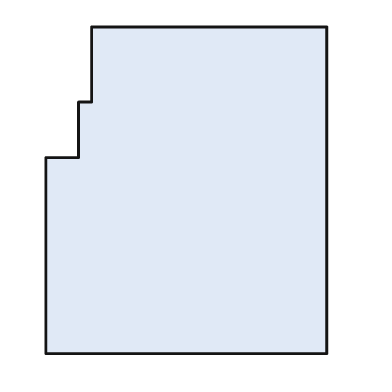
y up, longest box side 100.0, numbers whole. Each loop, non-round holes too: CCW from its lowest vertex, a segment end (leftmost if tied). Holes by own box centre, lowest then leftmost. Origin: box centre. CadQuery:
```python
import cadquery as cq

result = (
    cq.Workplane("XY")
    .moveTo(-43.0, -50.0)
    .lineTo(43.0, -50.0)
    .lineTo(43.0, 50.0)
    .lineTo(-29.0, 50.0)
    .lineTo(-29.0, 27.0)
    .lineTo(-33.0, 27.0)
    .lineTo(-33.0, 10.0)
    .lineTo(-43.0, 10.0)
    .close()
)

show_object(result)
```